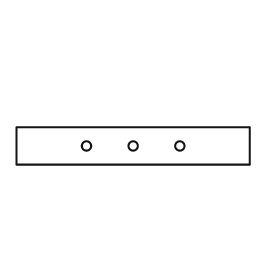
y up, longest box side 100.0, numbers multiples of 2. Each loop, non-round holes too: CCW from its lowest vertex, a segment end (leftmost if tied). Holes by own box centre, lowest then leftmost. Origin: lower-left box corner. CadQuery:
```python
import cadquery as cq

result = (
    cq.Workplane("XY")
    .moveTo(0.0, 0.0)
    .lineTo(100.0, 0.0)
    .lineTo(100.0, 16.0)
    .lineTo(0.0, 16.0)
    .close()
    .moveTo(30.0, 8.0)
    .circle(2.0)
    .moveTo(50.0, 8.0)
    .circle(2.0)
    .moveTo(70.0, 8.0)
    .circle(2.0)
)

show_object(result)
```